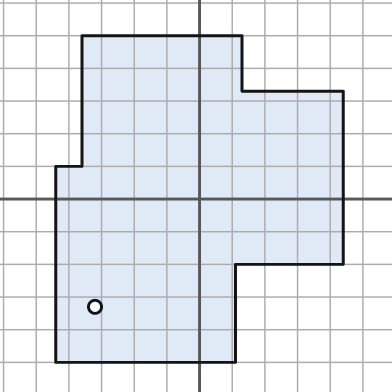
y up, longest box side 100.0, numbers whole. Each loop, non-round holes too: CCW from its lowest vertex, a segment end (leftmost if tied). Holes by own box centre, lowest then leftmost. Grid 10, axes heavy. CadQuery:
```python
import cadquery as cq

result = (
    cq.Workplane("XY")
    .moveTo(-44.0, -50.0)
    .lineTo(11.0, -50.0)
    .lineTo(11.0, -20.0)
    .lineTo(44.0, -20.0)
    .lineTo(44.0, 33.0)
    .lineTo(13.0, 33.0)
    .lineTo(13.0, 50.0)
    .lineTo(-36.0, 50.0)
    .lineTo(-36.0, 10.0)
    .lineTo(-44.0, 10.0)
    .close()
    .moveTo(-32.0, -33.0)
    .circle(2.0)
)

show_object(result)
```